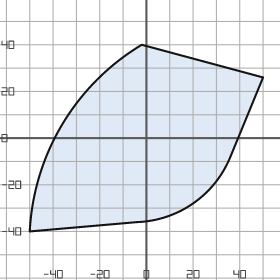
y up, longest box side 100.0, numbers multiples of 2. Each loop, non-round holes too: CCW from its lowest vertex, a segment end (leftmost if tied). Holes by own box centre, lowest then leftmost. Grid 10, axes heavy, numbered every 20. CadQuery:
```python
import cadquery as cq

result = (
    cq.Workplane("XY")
    .moveTo(-50.0, -40.0)
    .lineTo(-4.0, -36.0)
    .threePointArc((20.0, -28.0), (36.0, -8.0))
    .lineTo(50.0, 26.0)
    .lineTo(-2.0, 40.0)
    .threePointArc((-36.0, 6.0), (-50.0, -40.0))
    .close()
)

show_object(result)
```